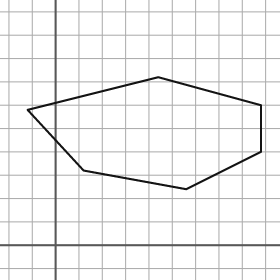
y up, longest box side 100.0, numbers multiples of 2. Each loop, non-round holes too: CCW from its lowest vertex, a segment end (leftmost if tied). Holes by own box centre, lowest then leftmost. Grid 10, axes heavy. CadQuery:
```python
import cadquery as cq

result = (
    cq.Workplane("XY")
    .moveTo(56.0, 24.0)
    .lineTo(88.0, 40.0)
    .lineTo(88.0, 60.0)
    .lineTo(44.0, 72.0)
    .lineTo(-12.0, 58.0)
    .lineTo(12.0, 32.0)
    .close()
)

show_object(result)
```